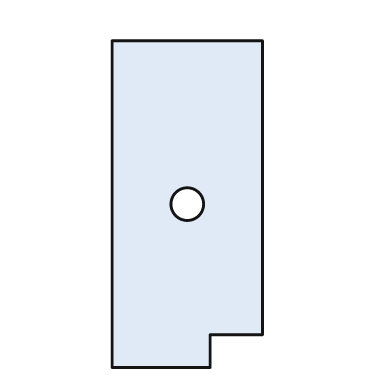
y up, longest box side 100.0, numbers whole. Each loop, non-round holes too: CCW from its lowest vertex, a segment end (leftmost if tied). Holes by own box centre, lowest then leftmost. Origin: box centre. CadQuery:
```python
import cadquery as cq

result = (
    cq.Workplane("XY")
    .moveTo(-23.0, -50.0)
    .lineTo(7.0, -50.0)
    .lineTo(7.0, -40.0)
    .lineTo(23.0, -40.0)
    .lineTo(23.0, 50.0)
    .lineTo(-23.0, 50.0)
    .close()
    .moveTo(0.0, 0.0)
    .circle(5.0)
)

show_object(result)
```